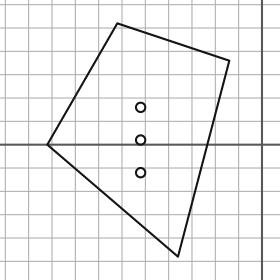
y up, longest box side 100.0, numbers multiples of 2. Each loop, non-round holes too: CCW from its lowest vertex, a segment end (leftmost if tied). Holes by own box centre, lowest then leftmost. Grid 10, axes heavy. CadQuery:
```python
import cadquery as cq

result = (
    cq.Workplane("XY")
    .moveTo(-36.0, -48.0)
    .lineTo(-14.0, 36.0)
    .lineTo(-62.0, 52.0)
    .lineTo(-92.0, 0.0)
    .close()
    .moveTo(-52.0, -12.0)
    .circle(2.0)
    .moveTo(-52.0, 2.0)
    .circle(2.0)
    .moveTo(-52.0, 16.0)
    .circle(2.0)
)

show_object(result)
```